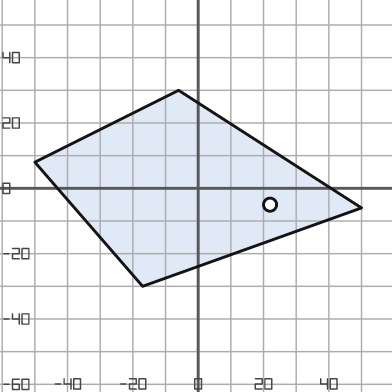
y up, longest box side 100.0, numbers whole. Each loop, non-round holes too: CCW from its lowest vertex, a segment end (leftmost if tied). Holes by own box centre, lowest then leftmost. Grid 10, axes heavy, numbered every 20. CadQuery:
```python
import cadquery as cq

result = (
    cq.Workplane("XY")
    .moveTo(-17.0, -30.0)
    .lineTo(50.0, -6.0)
    .lineTo(-6.0, 30.0)
    .lineTo(-50.0, 8.0)
    .close()
    .moveTo(22.0, -5.0)
    .circle(2.0)
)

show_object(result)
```